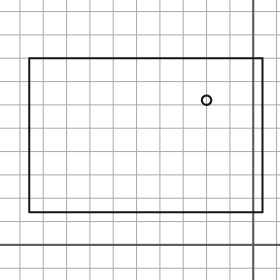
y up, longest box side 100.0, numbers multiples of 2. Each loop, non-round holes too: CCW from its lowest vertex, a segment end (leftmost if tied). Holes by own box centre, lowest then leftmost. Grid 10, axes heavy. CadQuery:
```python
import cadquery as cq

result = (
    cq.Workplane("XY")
    .moveTo(-96.0, 14.0)
    .lineTo(4.0, 14.0)
    .lineTo(4.0, 80.0)
    .lineTo(-96.0, 80.0)
    .close()
    .moveTo(-20.0, 62.0)
    .circle(2.0)
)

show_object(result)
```